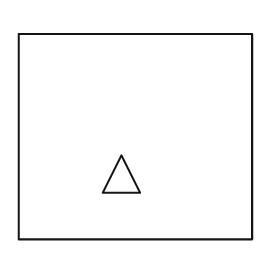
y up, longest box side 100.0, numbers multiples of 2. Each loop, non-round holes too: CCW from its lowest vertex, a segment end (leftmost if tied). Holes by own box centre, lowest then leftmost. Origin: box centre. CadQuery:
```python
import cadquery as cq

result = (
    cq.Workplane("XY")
    .moveTo(-50.0, -44.0)
    .lineTo(50.0, -44.0)
    .lineTo(50.0, 44.0)
    .lineTo(-50.0, 44.0)
    .close()
    .moveTo(-14.0, -24.0)
    .lineTo(2.0, -24.0)
    .lineTo(-6.0, -8.0)
    .close()
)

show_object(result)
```